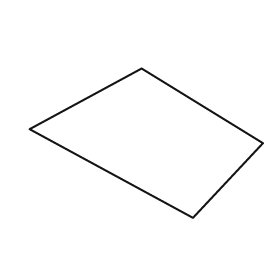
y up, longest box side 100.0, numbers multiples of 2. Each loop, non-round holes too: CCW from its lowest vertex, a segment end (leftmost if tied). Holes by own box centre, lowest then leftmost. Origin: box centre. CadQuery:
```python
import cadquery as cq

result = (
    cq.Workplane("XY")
    .moveTo(20.0, -32.0)
    .lineTo(50.0, 0.0)
    .lineTo(-2.0, 32.0)
    .lineTo(-50.0, 6.0)
    .close()
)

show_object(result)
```